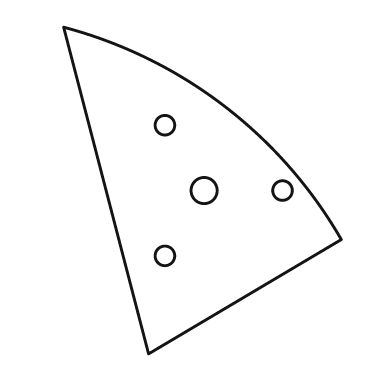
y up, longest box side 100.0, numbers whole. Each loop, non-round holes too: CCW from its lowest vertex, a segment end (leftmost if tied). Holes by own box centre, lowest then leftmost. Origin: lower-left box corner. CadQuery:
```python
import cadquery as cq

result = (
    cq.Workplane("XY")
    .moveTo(26.0, 0.0)
    .lineTo(85.0, 35.0)
    .threePointArc((49.0, 76.0), (0.0, 100.0))
    .close()
    .moveTo(31.0, 30.0)
    .circle(3.0)
    .moveTo(43.0, 50.0)
    .circle(4.0)
    .moveTo(67.0, 50.0)
    .circle(3.0)
    .moveTo(31.0, 70.0)
    .circle(3.0)
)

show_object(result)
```